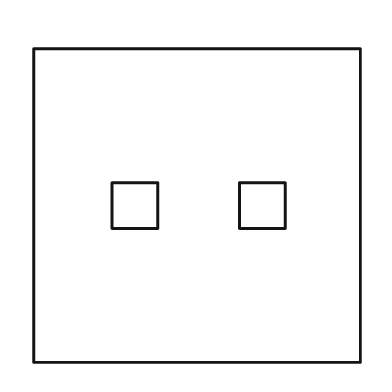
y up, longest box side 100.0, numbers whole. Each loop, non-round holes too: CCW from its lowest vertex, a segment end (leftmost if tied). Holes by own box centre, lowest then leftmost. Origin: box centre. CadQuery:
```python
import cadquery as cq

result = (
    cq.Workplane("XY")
    .moveTo(-50.0, -48.0)
    .lineTo(50.0, -48.0)
    .lineTo(50.0, 48.0)
    .lineTo(-50.0, 48.0)
    .close()
    .moveTo(-26.0, -7.0)
    .lineTo(-12.0, -7.0)
    .lineTo(-12.0, 7.0)
    .lineTo(-26.0, 7.0)
    .close()
    .moveTo(13.0, -7.0)
    .lineTo(27.0, -7.0)
    .lineTo(27.0, 7.0)
    .lineTo(13.0, 7.0)
    .close()
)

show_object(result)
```